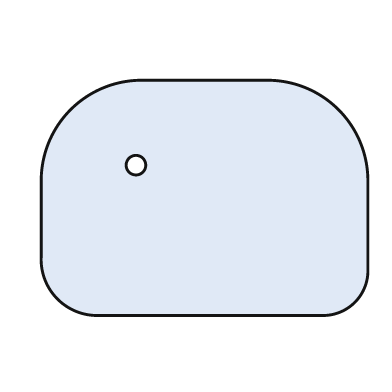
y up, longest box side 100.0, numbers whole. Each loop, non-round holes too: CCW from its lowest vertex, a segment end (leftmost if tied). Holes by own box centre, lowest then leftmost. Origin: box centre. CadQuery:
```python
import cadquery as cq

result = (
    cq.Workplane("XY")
    .moveTo(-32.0, -36.0)
    .lineTo(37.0, -36.0)
    .threePointArc((46.0, -32.0), (50.0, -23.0))
    .lineTo(50.0, 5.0)
    .threePointArc((41.0, 27.0), (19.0, 36.0))
    .lineTo(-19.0, 36.0)
    .threePointArc((-41.0, 27.0), (-50.0, 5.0))
    .lineTo(-50.0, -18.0)
    .threePointArc((-45.0, -31.0), (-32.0, -36.0))
    .close()
    .moveTo(-21.0, 10.0)
    .circle(3.0)
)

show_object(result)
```